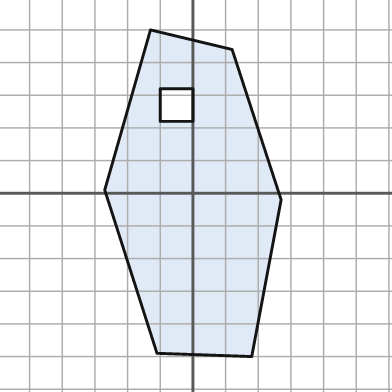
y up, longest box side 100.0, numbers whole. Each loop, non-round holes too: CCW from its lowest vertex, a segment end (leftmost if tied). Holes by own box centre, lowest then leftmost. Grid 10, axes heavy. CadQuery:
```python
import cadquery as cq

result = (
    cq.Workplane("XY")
    .moveTo(18.0, -50.0)
    .lineTo(27.0, -2.0)
    .lineTo(12.0, 44.0)
    .lineTo(-13.0, 50.0)
    .lineTo(-27.0, 1.0)
    .lineTo(-11.0, -49.0)
    .close()
    .moveTo(-10.0, 22.0)
    .lineTo(0.0, 22.0)
    .lineTo(0.0, 32.0)
    .lineTo(-10.0, 32.0)
    .close()
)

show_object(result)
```